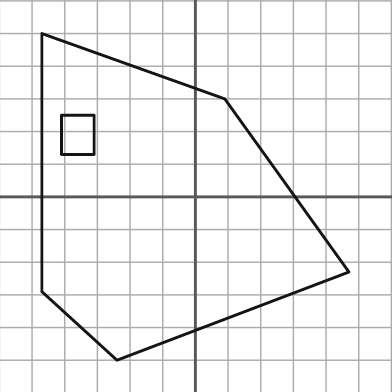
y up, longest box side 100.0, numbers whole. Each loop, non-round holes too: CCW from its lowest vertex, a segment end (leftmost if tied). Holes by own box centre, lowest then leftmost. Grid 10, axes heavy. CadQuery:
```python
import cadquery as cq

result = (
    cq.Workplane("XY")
    .moveTo(-24.0, -50.0)
    .lineTo(47.0, -23.0)
    .lineTo(9.0, 30.0)
    .lineTo(-47.0, 50.0)
    .lineTo(-47.0, -29.0)
    .close()
    .moveTo(-41.0, 13.0)
    .lineTo(-31.0, 13.0)
    .lineTo(-31.0, 25.0)
    .lineTo(-41.0, 25.0)
    .close()
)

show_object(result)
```